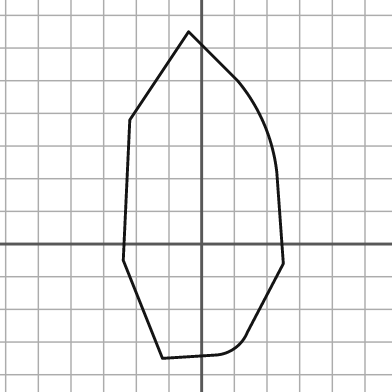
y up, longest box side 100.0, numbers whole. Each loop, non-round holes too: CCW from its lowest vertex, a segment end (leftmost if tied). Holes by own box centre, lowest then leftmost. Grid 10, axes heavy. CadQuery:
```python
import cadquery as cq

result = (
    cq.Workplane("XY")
    .moveTo(-12.0, -35.0)
    .lineTo(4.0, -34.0)
    .threePointArc((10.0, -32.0), (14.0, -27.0))
    .lineTo(25.0, -6.0)
    .lineTo(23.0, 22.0)
    .threePointArc((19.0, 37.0), (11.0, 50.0))
    .lineTo(-4.0, 65.0)
    .lineTo(-22.0, 38.0)
    .lineTo(-24.0, -5.0)
    .close()
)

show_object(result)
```